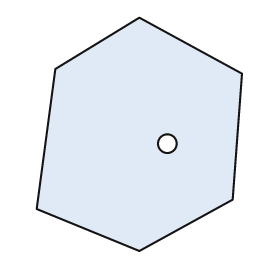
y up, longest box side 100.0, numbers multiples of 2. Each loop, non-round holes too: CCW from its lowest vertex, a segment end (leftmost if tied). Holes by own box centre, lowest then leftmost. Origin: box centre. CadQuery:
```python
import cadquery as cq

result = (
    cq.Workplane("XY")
    .moveTo(0.0, -50.0)
    .lineTo(40.0, -28.0)
    .lineTo(44.0, 26.0)
    .lineTo(0.0, 50.0)
    .lineTo(-36.0, 28.0)
    .lineTo(-44.0, -32.0)
    .close()
    .moveTo(12.0, -4.0)
    .circle(4.0)
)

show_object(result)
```